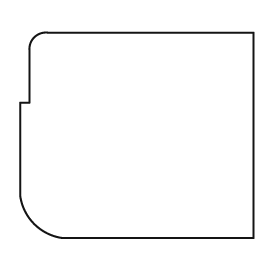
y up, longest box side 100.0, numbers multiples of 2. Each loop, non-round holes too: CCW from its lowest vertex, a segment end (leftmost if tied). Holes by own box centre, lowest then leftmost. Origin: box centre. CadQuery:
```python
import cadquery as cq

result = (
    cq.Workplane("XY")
    .moveTo(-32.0, -44.0)
    .lineTo(50.0, -44.0)
    .lineTo(50.0, 44.0)
    .lineTo(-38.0, 44.0)
    .threePointArc((-44.0, 42.0), (-46.0, 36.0))
    .lineTo(-46.0, 14.0)
    .lineTo(-50.0, 14.0)
    .lineTo(-50.0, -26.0)
    .threePointArc((-44.0, -38.0), (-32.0, -44.0))
    .close()
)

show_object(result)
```